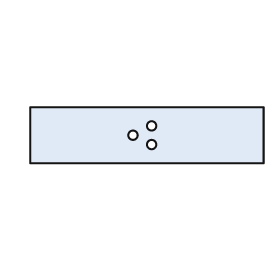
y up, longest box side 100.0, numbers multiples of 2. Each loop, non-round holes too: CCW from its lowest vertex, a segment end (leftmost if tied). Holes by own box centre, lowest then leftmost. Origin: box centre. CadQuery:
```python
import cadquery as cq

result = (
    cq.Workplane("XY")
    .moveTo(-50.0, -12.0)
    .lineTo(50.0, -12.0)
    .lineTo(50.0, 12.0)
    .lineTo(-50.0, 12.0)
    .close()
    .moveTo(2.0, -4.0)
    .circle(2.0)
    .moveTo(-6.0, 0.0)
    .circle(2.0)
    .moveTo(2.0, 4.0)
    .circle(2.0)
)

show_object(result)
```